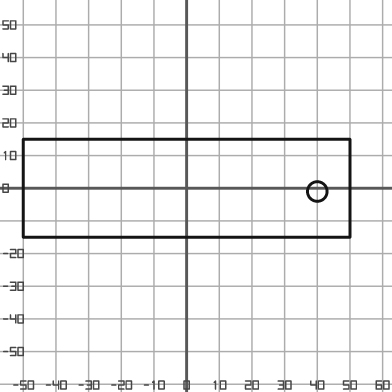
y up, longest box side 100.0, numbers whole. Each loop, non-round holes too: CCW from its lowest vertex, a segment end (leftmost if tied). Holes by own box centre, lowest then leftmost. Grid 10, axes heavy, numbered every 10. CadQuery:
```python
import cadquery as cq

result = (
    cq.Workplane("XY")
    .moveTo(-50.0, -15.0)
    .lineTo(50.0, -15.0)
    .lineTo(50.0, 15.0)
    .lineTo(-50.0, 15.0)
    .close()
    .moveTo(40.0, -1.0)
    .circle(3.0)
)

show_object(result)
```